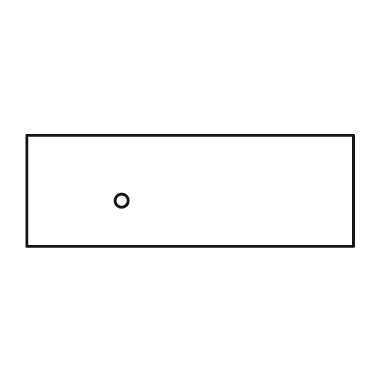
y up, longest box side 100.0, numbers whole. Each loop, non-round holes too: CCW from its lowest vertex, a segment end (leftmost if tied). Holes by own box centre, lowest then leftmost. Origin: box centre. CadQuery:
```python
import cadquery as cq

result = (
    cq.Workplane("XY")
    .moveTo(-50.0, -17.0)
    .lineTo(50.0, -17.0)
    .lineTo(50.0, 17.0)
    .lineTo(-50.0, 17.0)
    .close()
    .moveTo(-21.0, -3.0)
    .circle(2.0)
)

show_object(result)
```